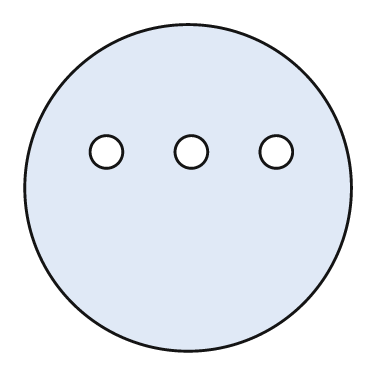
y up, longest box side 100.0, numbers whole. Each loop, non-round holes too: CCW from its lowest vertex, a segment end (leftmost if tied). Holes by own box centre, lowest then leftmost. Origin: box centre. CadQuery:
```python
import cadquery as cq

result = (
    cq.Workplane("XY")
    .moveTo(0.0, 0.0)
    .circle(50.0)
    .moveTo(-25.0, 11.0)
    .circle(5.0)
    .moveTo(1.0, 11.0)
    .circle(5.0)
    .moveTo(27.0, 11.0)
    .circle(5.0)
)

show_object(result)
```